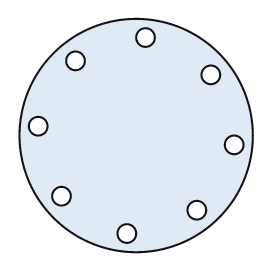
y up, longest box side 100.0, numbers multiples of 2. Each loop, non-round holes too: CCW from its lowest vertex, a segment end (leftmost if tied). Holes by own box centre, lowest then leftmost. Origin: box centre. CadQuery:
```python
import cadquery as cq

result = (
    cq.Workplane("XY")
    .moveTo(0.0, 0.0)
    .circle(50.0)
    .moveTo(-4.0, -42.0)
    .circle(4.0)
    .moveTo(26.0, -32.0)
    .circle(4.0)
    .moveTo(-32.0, -26.0)
    .circle(4.0)
    .moveTo(42.0, -4.0)
    .circle(4.0)
    .moveTo(-42.0, 4.0)
    .circle(4.0)
    .moveTo(32.0, 26.0)
    .circle(4.0)
    .moveTo(-26.0, 32.0)
    .circle(4.0)
    .moveTo(4.0, 42.0)
    .circle(4.0)
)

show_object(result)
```